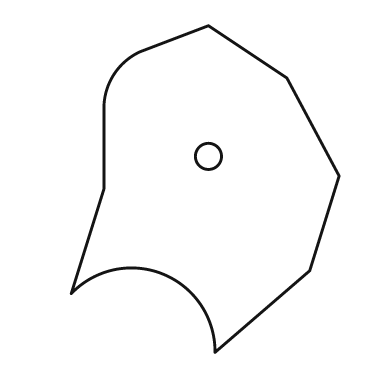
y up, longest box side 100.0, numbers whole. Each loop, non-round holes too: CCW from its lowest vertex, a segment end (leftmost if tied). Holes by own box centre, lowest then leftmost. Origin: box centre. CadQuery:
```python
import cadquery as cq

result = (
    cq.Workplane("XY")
    .moveTo(3.0, -50.0)
    .lineTo(32.0, -25.0)
    .lineTo(41.0, 4.0)
    .lineTo(25.0, 34.0)
    .lineTo(1.0, 50.0)
    .lineTo(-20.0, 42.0)
    .threePointArc((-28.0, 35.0), (-31.0, 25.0))
    .lineTo(-31.0, 0.0)
    .lineTo(-41.0, -32.0)
    .threePointArc((-13.0, -26.0), (3.0, -50.0))
    .close()
    .moveTo(1.0, 10.0)
    .circle(4.0)
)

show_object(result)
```